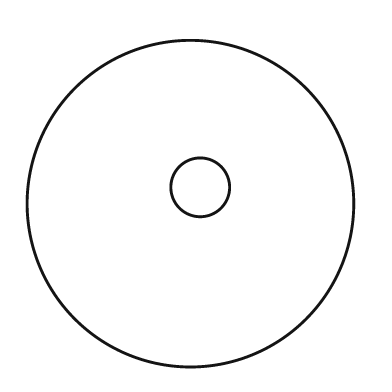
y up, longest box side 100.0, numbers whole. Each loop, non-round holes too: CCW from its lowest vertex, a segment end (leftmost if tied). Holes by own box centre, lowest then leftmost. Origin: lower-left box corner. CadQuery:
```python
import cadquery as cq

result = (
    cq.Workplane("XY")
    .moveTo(50.0, 50.0)
    .circle(50.0)
    .moveTo(53.0, 55.0)
    .circle(9.0)
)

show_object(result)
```